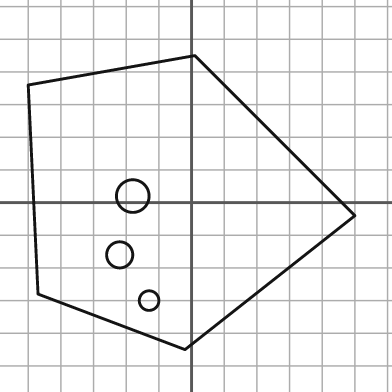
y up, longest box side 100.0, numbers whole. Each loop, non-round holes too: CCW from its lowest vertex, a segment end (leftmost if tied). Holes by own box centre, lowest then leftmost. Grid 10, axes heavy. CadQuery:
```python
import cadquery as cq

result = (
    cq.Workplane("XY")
    .moveTo(-2.0, -45.0)
    .lineTo(50.0, -4.0)
    .lineTo(1.0, 45.0)
    .lineTo(-50.0, 36.0)
    .lineTo(-47.0, -28.0)
    .close()
    .moveTo(-13.0, -30.0)
    .circle(3.0)
    .moveTo(-22.0, -16.0)
    .circle(4.0)
    .moveTo(-18.0, 2.0)
    .circle(5.0)
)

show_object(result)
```